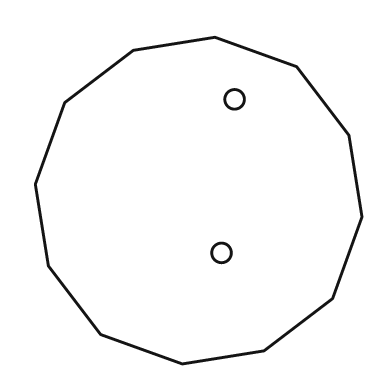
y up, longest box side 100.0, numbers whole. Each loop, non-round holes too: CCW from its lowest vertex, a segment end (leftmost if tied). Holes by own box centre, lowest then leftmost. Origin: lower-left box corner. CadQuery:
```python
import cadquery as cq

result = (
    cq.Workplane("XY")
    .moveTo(45.0, 0.0)
    .lineTo(70.0, 4.0)
    .lineTo(91.0, 20.0)
    .lineTo(100.0, 45.0)
    .lineTo(96.0, 70.0)
    .lineTo(80.0, 91.0)
    .lineTo(55.0, 100.0)
    .lineTo(30.0, 96.0)
    .lineTo(9.0, 80.0)
    .lineTo(0.0, 55.0)
    .lineTo(4.0, 30.0)
    .lineTo(20.0, 9.0)
    .close()
    .moveTo(57.0, 34.0)
    .circle(3.0)
    .moveTo(61.0, 81.0)
    .circle(3.0)
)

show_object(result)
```